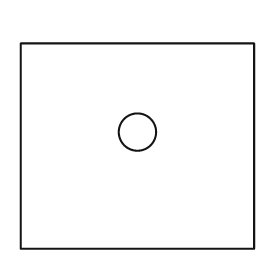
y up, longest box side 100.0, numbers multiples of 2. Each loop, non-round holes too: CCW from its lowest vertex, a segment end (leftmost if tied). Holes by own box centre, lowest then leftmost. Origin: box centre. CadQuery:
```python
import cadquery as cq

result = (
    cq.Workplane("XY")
    .moveTo(-50.0, -44.0)
    .lineTo(50.0, -44.0)
    .lineTo(50.0, 44.0)
    .lineTo(-50.0, 44.0)
    .close()
    .moveTo(0.0, 6.0)
    .circle(8.0)
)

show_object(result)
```